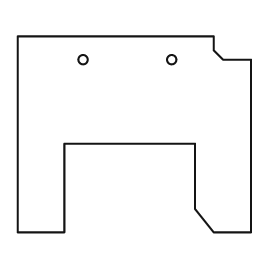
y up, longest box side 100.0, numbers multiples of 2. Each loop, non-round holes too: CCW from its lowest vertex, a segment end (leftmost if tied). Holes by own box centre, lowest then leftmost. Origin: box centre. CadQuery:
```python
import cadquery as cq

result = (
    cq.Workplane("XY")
    .moveTo(-50.0, -42.0)
    .lineTo(-30.0, -42.0)
    .lineTo(-30.0, -4.0)
    .lineTo(26.0, -4.0)
    .lineTo(26.0, -32.0)
    .lineTo(34.0, -42.0)
    .lineTo(50.0, -42.0)
    .lineTo(50.0, 32.0)
    .lineTo(38.0, 32.0)
    .lineTo(34.0, 36.0)
    .lineTo(34.0, 42.0)
    .lineTo(-50.0, 42.0)
    .close()
    .moveTo(-22.0, 32.0)
    .circle(2.0)
    .moveTo(16.0, 32.0)
    .circle(2.0)
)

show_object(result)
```